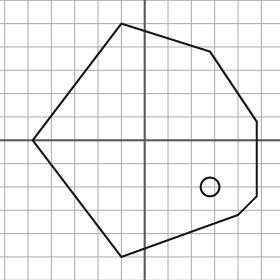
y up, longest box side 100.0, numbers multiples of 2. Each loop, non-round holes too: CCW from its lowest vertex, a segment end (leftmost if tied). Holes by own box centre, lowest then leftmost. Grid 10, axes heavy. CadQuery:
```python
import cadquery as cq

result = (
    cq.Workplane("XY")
    .moveTo(-10.0, -50.0)
    .lineTo(40.0, -32.0)
    .lineTo(48.0, -24.0)
    .lineTo(48.0, 8.0)
    .lineTo(28.0, 38.0)
    .lineTo(-10.0, 50.0)
    .lineTo(-48.0, 0.0)
    .close()
    .moveTo(28.0, -20.0)
    .circle(4.0)
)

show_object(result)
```